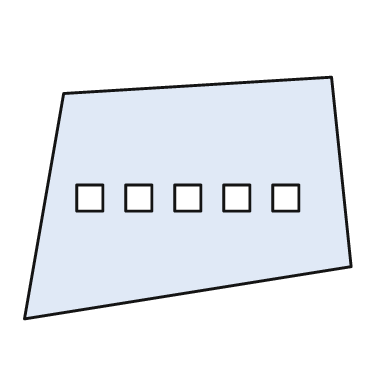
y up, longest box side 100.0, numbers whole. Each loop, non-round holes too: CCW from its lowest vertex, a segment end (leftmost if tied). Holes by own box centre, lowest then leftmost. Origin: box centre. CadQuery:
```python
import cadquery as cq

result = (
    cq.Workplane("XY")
    .moveTo(-50.0, -37.0)
    .lineTo(50.0, -21.0)
    .lineTo(44.0, 37.0)
    .lineTo(-38.0, 32.0)
    .close()
    .moveTo(-34.0, -4.0)
    .lineTo(-26.0, -4.0)
    .lineTo(-26.0, 4.0)
    .lineTo(-34.0, 4.0)
    .close()
    .moveTo(-19.0, -4.0)
    .lineTo(-11.0, -4.0)
    .lineTo(-11.0, 4.0)
    .lineTo(-19.0, 4.0)
    .close()
    .moveTo(-4.0, -4.0)
    .lineTo(4.0, -4.0)
    .lineTo(4.0, 4.0)
    .lineTo(-4.0, 4.0)
    .close()
    .moveTo(11.0, -4.0)
    .lineTo(19.0, -4.0)
    .lineTo(19.0, 4.0)
    .lineTo(11.0, 4.0)
    .close()
    .moveTo(26.0, -4.0)
    .lineTo(34.0, -4.0)
    .lineTo(34.0, 4.0)
    .lineTo(26.0, 4.0)
    .close()
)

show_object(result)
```